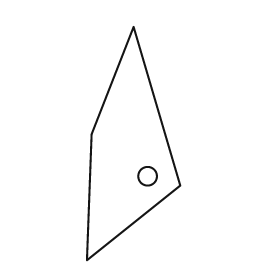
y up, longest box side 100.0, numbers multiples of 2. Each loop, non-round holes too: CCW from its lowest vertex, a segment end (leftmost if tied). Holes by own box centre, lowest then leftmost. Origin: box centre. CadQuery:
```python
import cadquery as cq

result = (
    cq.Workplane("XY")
    .moveTo(-20.0, -50.0)
    .lineTo(20.0, -18.0)
    .lineTo(0.0, 50.0)
    .lineTo(-18.0, 4.0)
    .close()
    .moveTo(6.0, -14.0)
    .circle(4.0)
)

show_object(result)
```